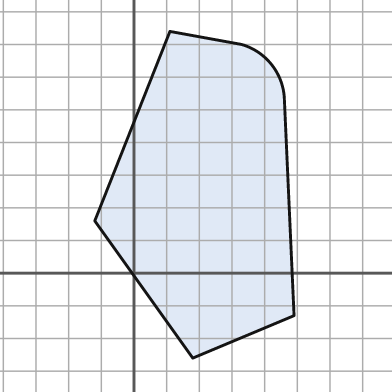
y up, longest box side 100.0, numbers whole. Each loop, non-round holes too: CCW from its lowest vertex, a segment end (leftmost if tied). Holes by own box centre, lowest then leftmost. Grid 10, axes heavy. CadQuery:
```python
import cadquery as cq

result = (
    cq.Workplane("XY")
    .moveTo(18.0, -26.0)
    .lineTo(49.0, -13.0)
    .lineTo(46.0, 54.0)
    .threePointArc((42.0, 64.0), (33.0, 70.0))
    .lineTo(11.0, 74.0)
    .lineTo(-12.0, 16.0)
    .close()
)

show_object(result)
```